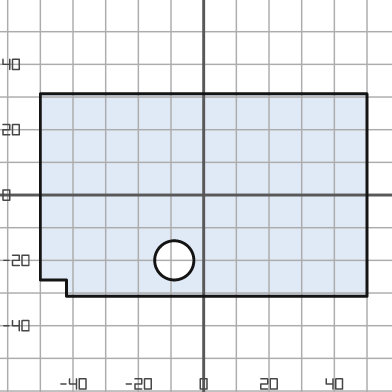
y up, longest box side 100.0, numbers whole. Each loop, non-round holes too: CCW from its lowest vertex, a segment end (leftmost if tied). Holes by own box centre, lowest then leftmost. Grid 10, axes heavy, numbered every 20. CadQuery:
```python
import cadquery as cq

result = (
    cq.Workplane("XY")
    .moveTo(-42.0, -31.0)
    .lineTo(50.0, -31.0)
    .lineTo(50.0, 31.0)
    .lineTo(-50.0, 31.0)
    .lineTo(-50.0, -26.0)
    .lineTo(-42.0, -26.0)
    .close()
    .moveTo(-9.0, -20.0)
    .circle(6.0)
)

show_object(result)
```